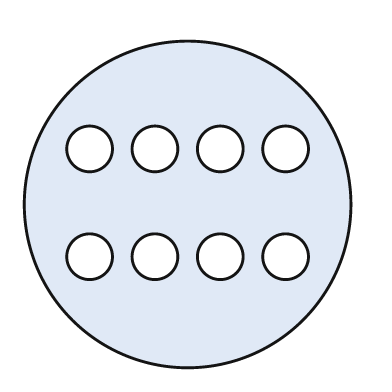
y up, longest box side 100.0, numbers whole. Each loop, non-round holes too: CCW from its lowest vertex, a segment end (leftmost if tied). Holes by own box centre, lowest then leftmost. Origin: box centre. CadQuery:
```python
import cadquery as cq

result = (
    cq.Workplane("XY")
    .moveTo(0.0, 0.0)
    .circle(50.0)
    .moveTo(-30.0, -16.0)
    .circle(7.0)
    .moveTo(-10.0, -16.0)
    .circle(7.0)
    .moveTo(10.0, -16.0)
    .circle(7.0)
    .moveTo(30.0, -16.0)
    .circle(7.0)
    .moveTo(-30.0, 17.0)
    .circle(7.0)
    .moveTo(-10.0, 17.0)
    .circle(7.0)
    .moveTo(10.0, 17.0)
    .circle(7.0)
    .moveTo(30.0, 17.0)
    .circle(7.0)
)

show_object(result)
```